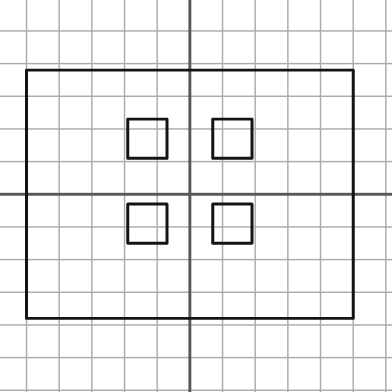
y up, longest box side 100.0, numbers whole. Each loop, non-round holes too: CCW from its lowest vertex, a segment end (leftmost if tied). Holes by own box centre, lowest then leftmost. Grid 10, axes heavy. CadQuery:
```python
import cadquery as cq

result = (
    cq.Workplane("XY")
    .moveTo(-50.0, -38.0)
    .lineTo(50.0, -38.0)
    .lineTo(50.0, 38.0)
    .lineTo(-50.0, 38.0)
    .close()
    .moveTo(-19.0, -15.0)
    .lineTo(-7.0, -15.0)
    .lineTo(-7.0, -3.0)
    .lineTo(-19.0, -3.0)
    .close()
    .moveTo(7.0, -15.0)
    .lineTo(19.0, -15.0)
    .lineTo(19.0, -3.0)
    .lineTo(7.0, -3.0)
    .close()
    .moveTo(-19.0, 11.0)
    .lineTo(-7.0, 11.0)
    .lineTo(-7.0, 23.0)
    .lineTo(-19.0, 23.0)
    .close()
    .moveTo(7.0, 11.0)
    .lineTo(19.0, 11.0)
    .lineTo(19.0, 23.0)
    .lineTo(7.0, 23.0)
    .close()
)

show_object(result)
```